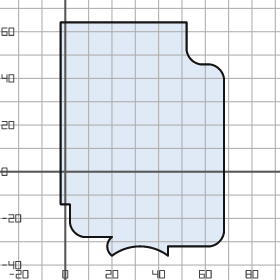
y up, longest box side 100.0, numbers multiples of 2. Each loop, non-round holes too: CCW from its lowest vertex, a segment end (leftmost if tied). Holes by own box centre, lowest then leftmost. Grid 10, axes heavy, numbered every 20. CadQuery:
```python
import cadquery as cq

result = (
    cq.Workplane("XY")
    .moveTo(20.0, -36.0)
    .threePointArc((32.0, -32.0), (44.0, -36.0))
    .lineTo(44.0, -32.0)
    .lineTo(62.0, -32.0)
    .threePointArc((66.0, -30.0), (68.0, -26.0))
    .lineTo(68.0, 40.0)
    .threePointArc((66.0, 44.0), (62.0, 46.0))
    .lineTo(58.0, 46.0)
    .threePointArc((54.0, 48.0), (52.0, 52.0))
    .lineTo(52.0, 64.0)
    .lineTo(-2.0, 64.0)
    .lineTo(-2.0, -14.0)
    .lineTo(2.0, -14.0)
    .lineTo(2.0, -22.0)
    .threePointArc((4.0, -26.0), (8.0, -28.0))
    .lineTo(20.0, -28.0)
    .threePointArc((18.0, -32.0), (20.0, -36.0))
    .close()
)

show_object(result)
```